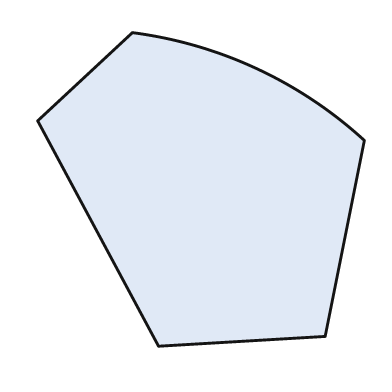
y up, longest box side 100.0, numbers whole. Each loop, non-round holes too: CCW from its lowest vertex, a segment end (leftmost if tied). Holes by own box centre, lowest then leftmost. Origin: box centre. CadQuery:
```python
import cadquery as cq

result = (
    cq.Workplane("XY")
    .moveTo(-13.0, -48.0)
    .lineTo(38.0, -45.0)
    .lineTo(50.0, 15.0)
    .threePointArc((17.0, 37.0), (-21.0, 48.0))
    .lineTo(-50.0, 21.0)
    .close()
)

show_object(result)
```